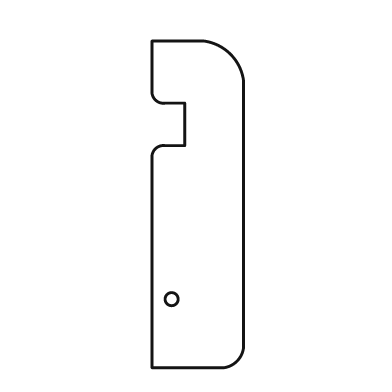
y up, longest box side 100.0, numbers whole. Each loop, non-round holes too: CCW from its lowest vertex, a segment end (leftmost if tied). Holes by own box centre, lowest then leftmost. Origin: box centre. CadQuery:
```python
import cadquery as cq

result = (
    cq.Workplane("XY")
    .moveTo(-14.0, -50.0)
    .lineTo(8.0, -50.0)
    .threePointArc((12.0, -48.0), (14.0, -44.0))
    .lineTo(14.0, 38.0)
    .threePointArc((10.0, 46.0), (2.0, 50.0))
    .lineTo(-14.0, 50.0)
    .lineTo(-14.0, 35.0)
    .threePointArc((-13.0, 32.0), (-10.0, 31.0))
    .lineTo(-4.0, 31.0)
    .lineTo(-4.0, 18.0)
    .lineTo(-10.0, 18.0)
    .threePointArc((-13.0, 17.0), (-14.0, 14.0))
    .close()
    .moveTo(-8.0, -29.0)
    .circle(2.0)
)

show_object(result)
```